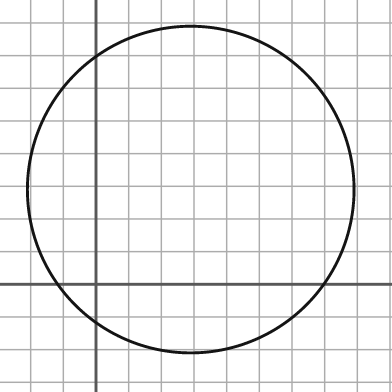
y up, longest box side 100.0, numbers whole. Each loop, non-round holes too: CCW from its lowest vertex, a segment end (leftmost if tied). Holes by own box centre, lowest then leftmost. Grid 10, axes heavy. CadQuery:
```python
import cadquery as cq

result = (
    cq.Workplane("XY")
    .moveTo(29.0, 29.0)
    .circle(50.0)
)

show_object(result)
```